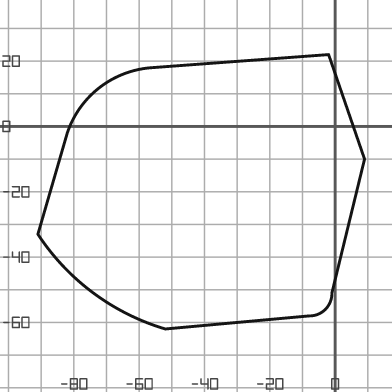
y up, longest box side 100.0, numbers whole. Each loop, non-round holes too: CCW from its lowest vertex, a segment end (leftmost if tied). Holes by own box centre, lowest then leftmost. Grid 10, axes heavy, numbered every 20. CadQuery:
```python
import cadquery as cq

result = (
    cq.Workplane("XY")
    .moveTo(-52.0, -62.0)
    .lineTo(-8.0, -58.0)
    .threePointArc((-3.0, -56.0), (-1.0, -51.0))
    .lineTo(9.0, -10.0)
    .lineTo(-2.0, 22.0)
    .lineTo(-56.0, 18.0)
    .threePointArc((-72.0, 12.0), (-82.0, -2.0))
    .lineTo(-91.0, -33.0)
    .threePointArc((-74.0, -51.0), (-52.0, -62.0))
    .close()
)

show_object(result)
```